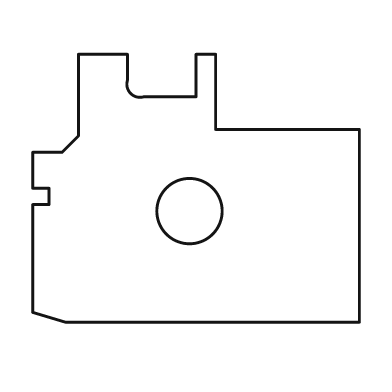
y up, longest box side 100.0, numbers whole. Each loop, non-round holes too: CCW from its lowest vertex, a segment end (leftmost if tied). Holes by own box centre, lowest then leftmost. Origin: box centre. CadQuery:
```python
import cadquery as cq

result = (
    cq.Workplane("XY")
    .moveTo(-40.0, -41.0)
    .lineTo(50.0, -41.0)
    .lineTo(50.0, 18.0)
    .lineTo(6.0, 18.0)
    .lineTo(6.0, 41.0)
    .lineTo(0.0, 41.0)
    .lineTo(0.0, 28.0)
    .lineTo(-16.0, 28.0)
    .threePointArc((-20.0, 29.0), (-21.0, 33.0))
    .lineTo(-21.0, 41.0)
    .lineTo(-36.0, 41.0)
    .lineTo(-36.0, 16.0)
    .lineTo(-41.0, 11.0)
    .lineTo(-50.0, 11.0)
    .lineTo(-50.0, 0.0)
    .lineTo(-45.0, 0.0)
    .lineTo(-45.0, -5.0)
    .lineTo(-50.0, -5.0)
    .lineTo(-50.0, -38.0)
    .close()
    .moveTo(-2.0, -7.0)
    .circle(10.0)
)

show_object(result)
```